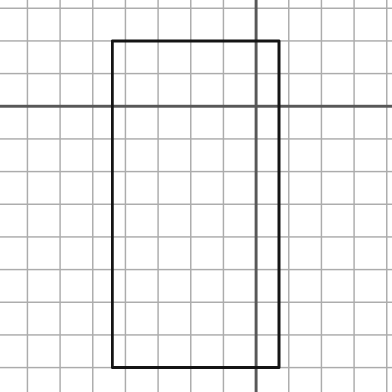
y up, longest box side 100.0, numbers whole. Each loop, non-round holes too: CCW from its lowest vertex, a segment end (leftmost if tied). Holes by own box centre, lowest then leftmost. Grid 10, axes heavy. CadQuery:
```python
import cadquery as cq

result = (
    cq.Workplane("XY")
    .moveTo(-44.0, -80.0)
    .lineTo(7.0, -80.0)
    .lineTo(7.0, 20.0)
    .lineTo(-44.0, 20.0)
    .close()
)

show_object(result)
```